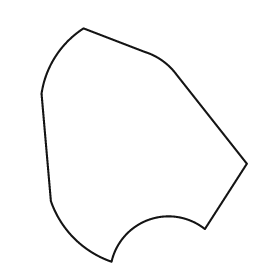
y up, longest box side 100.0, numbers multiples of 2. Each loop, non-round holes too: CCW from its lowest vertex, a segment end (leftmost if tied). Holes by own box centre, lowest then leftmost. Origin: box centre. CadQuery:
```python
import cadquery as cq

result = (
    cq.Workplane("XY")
    .moveTo(-14.0, -50.0)
    .threePointArc((2.0, -32.0), (26.0, -36.0))
    .lineTo(44.0, -8.0)
    .lineTo(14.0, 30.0)
    .threePointArc((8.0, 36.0), (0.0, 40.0))
    .lineTo(-26.0, 50.0)
    .threePointArc((-38.0, 38.0), (-44.0, 22.0))
    .lineTo(-40.0, -24.0)
    .threePointArc((-30.0, -40.0), (-14.0, -50.0))
    .close()
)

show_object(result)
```